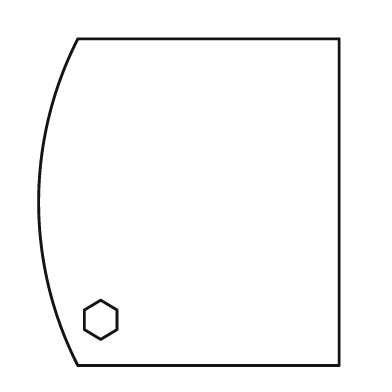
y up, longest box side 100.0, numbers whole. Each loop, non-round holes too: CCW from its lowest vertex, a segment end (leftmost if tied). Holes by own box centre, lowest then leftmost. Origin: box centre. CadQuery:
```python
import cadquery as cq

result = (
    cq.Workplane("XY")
    .moveTo(-34.0, -50.0)
    .lineTo(46.0, -50.0)
    .lineTo(46.0, 50.0)
    .lineTo(-34.0, 50.0)
    .threePointArc((-46.0, 0.0), (-34.0, -50.0))
    .close()
    .moveTo(-27.0, -42.0)
    .lineTo(-22.0, -39.0)
    .lineTo(-22.0, -33.0)
    .lineTo(-27.0, -30.0)
    .lineTo(-32.0, -33.0)
    .lineTo(-32.0, -39.0)
    .close()
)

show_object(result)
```